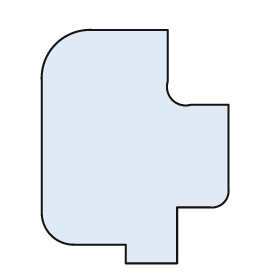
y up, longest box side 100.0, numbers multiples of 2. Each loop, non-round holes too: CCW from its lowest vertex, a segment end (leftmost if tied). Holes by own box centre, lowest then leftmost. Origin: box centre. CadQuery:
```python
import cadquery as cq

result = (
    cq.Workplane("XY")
    .moveTo(-4.0, -50.0)
    .lineTo(18.0, -50.0)
    .lineTo(18.0, -26.0)
    .lineTo(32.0, -26.0)
    .threePointArc((38.0, -24.0), (40.0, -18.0))
    .lineTo(40.0, 18.0)
    .lineTo(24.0, 18.0)
    .threePointArc((16.0, 20.0), (14.0, 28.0))
    .lineTo(14.0, 50.0)
    .lineTo(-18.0, 50.0)
    .threePointArc((-34.0, 44.0), (-40.0, 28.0))
    .lineTo(-40.0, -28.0)
    .threePointArc((-36.0, -38.0), (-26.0, -42.0))
    .lineTo(-4.0, -42.0)
    .close()
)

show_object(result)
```